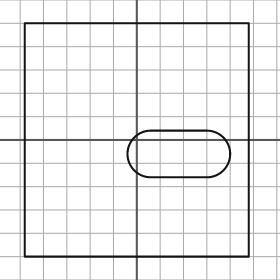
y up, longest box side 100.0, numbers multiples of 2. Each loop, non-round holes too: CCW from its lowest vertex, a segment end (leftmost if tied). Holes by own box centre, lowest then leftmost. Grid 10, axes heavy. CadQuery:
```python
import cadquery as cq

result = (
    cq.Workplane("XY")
    .moveTo(-48.0, -50.0)
    .lineTo(48.0, -50.0)
    .lineTo(48.0, 50.0)
    .lineTo(-48.0, 50.0)
    .close()
    .moveTo(6.0, -16.0)
    .lineTo(30.0, -16.0)
    .threePointArc((40.0, -6.0), (30.0, 4.0))
    .lineTo(6.0, 4.0)
    .threePointArc((-4.0, -6.0), (6.0, -16.0))
    .close()
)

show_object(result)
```